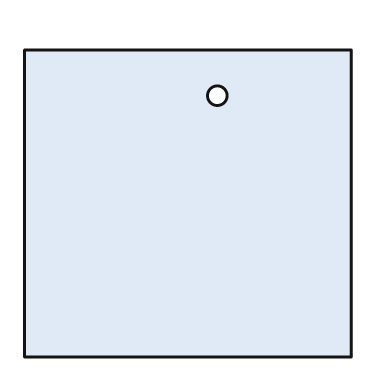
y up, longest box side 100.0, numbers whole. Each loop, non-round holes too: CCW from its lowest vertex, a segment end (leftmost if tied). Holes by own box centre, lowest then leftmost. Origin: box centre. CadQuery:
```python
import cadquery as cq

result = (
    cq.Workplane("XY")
    .moveTo(-50.0, -47.0)
    .lineTo(50.0, -47.0)
    .lineTo(50.0, 47.0)
    .lineTo(-50.0, 47.0)
    .close()
    .moveTo(9.0, 33.0)
    .circle(3.0)
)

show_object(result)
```